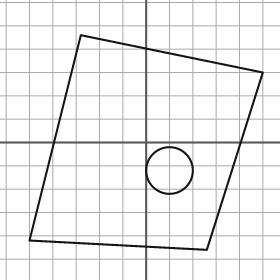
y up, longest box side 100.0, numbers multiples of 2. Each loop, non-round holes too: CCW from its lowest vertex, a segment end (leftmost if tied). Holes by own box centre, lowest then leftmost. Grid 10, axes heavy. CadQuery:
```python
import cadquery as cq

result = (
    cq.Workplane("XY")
    .moveTo(26.0, -46.0)
    .lineTo(50.0, 30.0)
    .lineTo(-28.0, 46.0)
    .lineTo(-50.0, -42.0)
    .close()
    .moveTo(10.0, -12.0)
    .circle(10.0)
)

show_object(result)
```